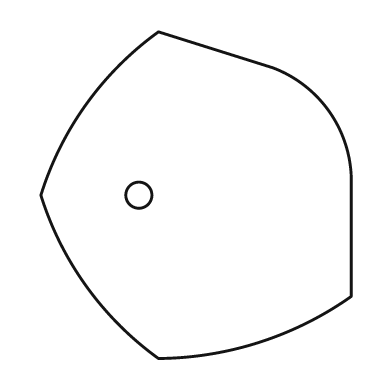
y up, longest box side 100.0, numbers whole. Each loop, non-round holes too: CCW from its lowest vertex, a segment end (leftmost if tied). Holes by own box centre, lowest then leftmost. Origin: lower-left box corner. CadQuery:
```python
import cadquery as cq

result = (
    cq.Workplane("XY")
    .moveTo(36.0, 0.0)
    .threePointArc((67.0, 5.0), (95.0, 19.0))
    .lineTo(95.0, 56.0)
    .threePointArc((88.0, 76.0), (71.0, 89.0))
    .lineTo(36.0, 100.0)
    .threePointArc((14.0, 78.0), (0.0, 50.0))
    .threePointArc((14.0, 22.0), (36.0, 0.0))
    .close()
    .moveTo(30.0, 50.0)
    .circle(4.0)
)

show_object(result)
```